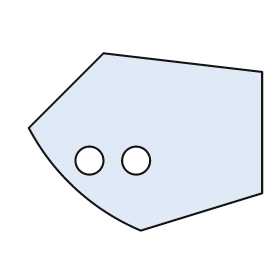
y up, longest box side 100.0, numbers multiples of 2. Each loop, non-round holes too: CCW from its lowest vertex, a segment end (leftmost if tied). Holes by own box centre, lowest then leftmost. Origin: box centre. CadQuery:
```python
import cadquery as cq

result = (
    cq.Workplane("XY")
    .moveTo(-2.0, -38.0)
    .lineTo(50.0, -22.0)
    .lineTo(50.0, 30.0)
    .lineTo(-18.0, 38.0)
    .lineTo(-50.0, 6.0)
    .threePointArc((-30.0, -20.0), (-2.0, -38.0))
    .close()
    .moveTo(-24.0, -8.0)
    .circle(6.0)
    .moveTo(-4.0, -8.0)
    .circle(6.0)
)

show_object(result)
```